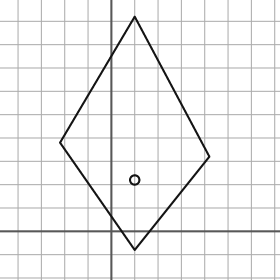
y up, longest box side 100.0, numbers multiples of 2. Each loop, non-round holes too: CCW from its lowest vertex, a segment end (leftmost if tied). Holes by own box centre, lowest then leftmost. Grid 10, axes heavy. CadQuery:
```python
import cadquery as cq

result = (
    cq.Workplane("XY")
    .moveTo(10.0, -8.0)
    .lineTo(42.0, 32.0)
    .lineTo(10.0, 92.0)
    .lineTo(-22.0, 38.0)
    .close()
    .moveTo(10.0, 22.0)
    .circle(2.0)
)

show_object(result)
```